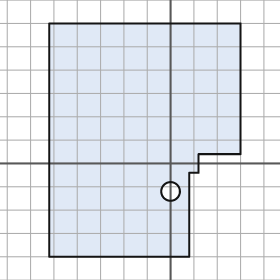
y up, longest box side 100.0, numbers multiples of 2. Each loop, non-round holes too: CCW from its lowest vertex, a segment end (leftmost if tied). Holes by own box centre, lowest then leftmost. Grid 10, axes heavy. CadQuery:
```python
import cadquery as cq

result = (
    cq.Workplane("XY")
    .moveTo(-52.0, -40.0)
    .lineTo(8.0, -40.0)
    .lineTo(8.0, -4.0)
    .lineTo(12.0, -4.0)
    .lineTo(12.0, 4.0)
    .lineTo(30.0, 4.0)
    .lineTo(30.0, 60.0)
    .lineTo(-52.0, 60.0)
    .close()
    .moveTo(0.0, -12.0)
    .circle(4.0)
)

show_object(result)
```